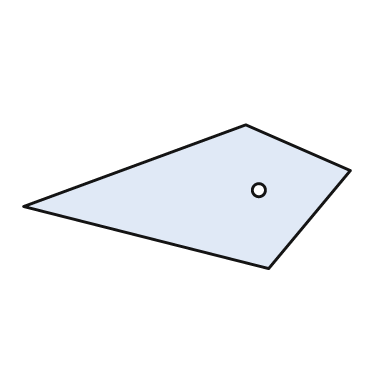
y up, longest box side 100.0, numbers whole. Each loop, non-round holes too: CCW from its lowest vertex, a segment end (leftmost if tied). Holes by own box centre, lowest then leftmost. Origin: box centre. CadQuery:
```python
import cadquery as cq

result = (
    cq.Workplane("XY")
    .moveTo(25.0, -22.0)
    .lineTo(50.0, 8.0)
    .lineTo(18.0, 22.0)
    .lineTo(-50.0, -3.0)
    .close()
    .moveTo(22.0, 2.0)
    .circle(2.0)
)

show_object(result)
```